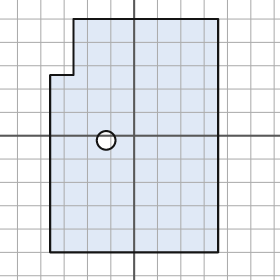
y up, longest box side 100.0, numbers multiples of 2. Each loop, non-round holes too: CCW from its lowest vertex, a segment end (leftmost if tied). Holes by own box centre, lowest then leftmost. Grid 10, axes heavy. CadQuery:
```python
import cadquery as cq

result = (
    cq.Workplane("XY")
    .moveTo(-36.0, -50.0)
    .lineTo(36.0, -50.0)
    .lineTo(36.0, 50.0)
    .lineTo(-26.0, 50.0)
    .lineTo(-26.0, 26.0)
    .lineTo(-36.0, 26.0)
    .close()
    .moveTo(-12.0, -2.0)
    .circle(4.0)
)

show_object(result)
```